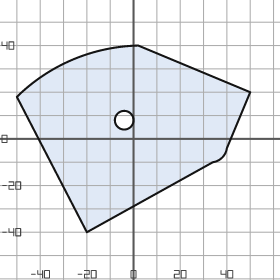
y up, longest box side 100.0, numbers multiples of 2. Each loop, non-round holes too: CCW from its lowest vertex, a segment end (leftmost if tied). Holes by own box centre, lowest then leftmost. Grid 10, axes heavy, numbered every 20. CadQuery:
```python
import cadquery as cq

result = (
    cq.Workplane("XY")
    .moveTo(-20.0, -40.0)
    .lineTo(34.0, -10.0)
    .threePointArc((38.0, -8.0), (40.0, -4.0))
    .lineTo(50.0, 20.0)
    .lineTo(2.0, 40.0)
    .threePointArc((-26.0, 34.0), (-50.0, 18.0))
    .close()
    .moveTo(-4.0, 8.0)
    .circle(4.0)
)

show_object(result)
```